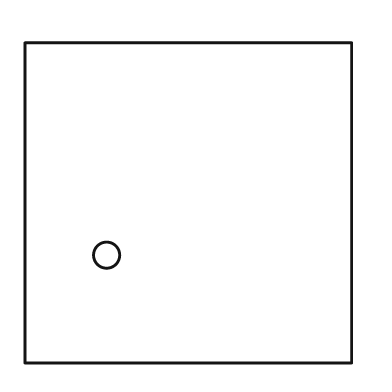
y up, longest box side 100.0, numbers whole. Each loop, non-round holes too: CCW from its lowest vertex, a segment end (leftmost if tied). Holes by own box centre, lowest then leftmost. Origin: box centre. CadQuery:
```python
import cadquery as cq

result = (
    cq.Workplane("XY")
    .moveTo(-50.0, -49.0)
    .lineTo(50.0, -49.0)
    .lineTo(50.0, 49.0)
    .lineTo(-50.0, 49.0)
    .close()
    .moveTo(-25.0, -16.0)
    .circle(4.0)
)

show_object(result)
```